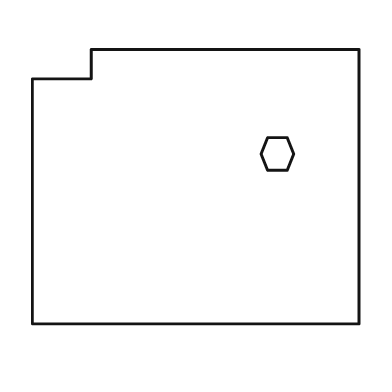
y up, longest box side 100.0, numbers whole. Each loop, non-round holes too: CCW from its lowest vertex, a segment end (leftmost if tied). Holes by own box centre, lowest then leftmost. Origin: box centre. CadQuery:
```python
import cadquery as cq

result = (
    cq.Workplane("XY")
    .moveTo(-50.0, -42.0)
    .lineTo(50.0, -42.0)
    .lineTo(50.0, 42.0)
    .lineTo(-32.0, 42.0)
    .lineTo(-32.0, 33.0)
    .lineTo(-50.0, 33.0)
    .close()
    .moveTo(22.0, 5.0)
    .lineTo(28.0, 5.0)
    .lineTo(30.0, 10.0)
    .lineTo(28.0, 15.0)
    .lineTo(22.0, 15.0)
    .lineTo(20.0, 10.0)
    .close()
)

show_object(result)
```